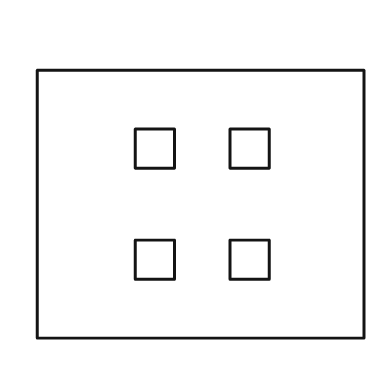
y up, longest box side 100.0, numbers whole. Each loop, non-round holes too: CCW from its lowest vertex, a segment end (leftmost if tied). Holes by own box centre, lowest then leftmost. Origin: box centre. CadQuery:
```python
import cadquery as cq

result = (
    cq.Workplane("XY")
    .moveTo(-50.0, -41.0)
    .lineTo(50.0, -41.0)
    .lineTo(50.0, 41.0)
    .lineTo(-50.0, 41.0)
    .close()
    .moveTo(-20.0, -23.0)
    .lineTo(-8.0, -23.0)
    .lineTo(-8.0, -11.0)
    .lineTo(-20.0, -11.0)
    .close()
    .moveTo(9.0, -23.0)
    .lineTo(21.0, -23.0)
    .lineTo(21.0, -11.0)
    .lineTo(9.0, -11.0)
    .close()
    .moveTo(-20.0, 11.0)
    .lineTo(-8.0, 11.0)
    .lineTo(-8.0, 23.0)
    .lineTo(-20.0, 23.0)
    .close()
    .moveTo(9.0, 11.0)
    .lineTo(21.0, 11.0)
    .lineTo(21.0, 23.0)
    .lineTo(9.0, 23.0)
    .close()
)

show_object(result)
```